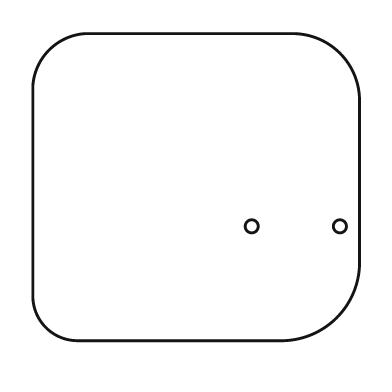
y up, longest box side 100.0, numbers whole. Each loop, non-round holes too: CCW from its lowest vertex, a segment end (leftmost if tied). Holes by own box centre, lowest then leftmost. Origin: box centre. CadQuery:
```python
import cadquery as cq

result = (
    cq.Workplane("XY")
    .moveTo(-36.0, -47.0)
    .lineTo(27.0, -47.0)
    .threePointArc((43.0, -40.0), (50.0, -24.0))
    .lineTo(50.0, 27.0)
    .threePointArc((44.0, 41.0), (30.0, 47.0))
    .lineTo(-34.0, 47.0)
    .threePointArc((-45.0, 42.0), (-50.0, 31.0))
    .lineTo(-50.0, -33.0)
    .threePointArc((-46.0, -43.0), (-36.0, -47.0))
    .close()
    .moveTo(17.0, -12.0)
    .circle(2.0)
    .moveTo(44.0, -12.0)
    .circle(2.0)
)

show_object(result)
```